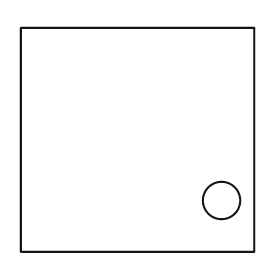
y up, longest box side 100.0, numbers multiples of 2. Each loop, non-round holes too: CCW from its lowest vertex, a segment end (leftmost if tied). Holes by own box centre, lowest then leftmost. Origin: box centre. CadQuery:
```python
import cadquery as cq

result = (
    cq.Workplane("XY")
    .moveTo(-50.0, -48.0)
    .lineTo(50.0, -48.0)
    .lineTo(50.0, 48.0)
    .lineTo(-50.0, 48.0)
    .close()
    .moveTo(36.0, -26.0)
    .circle(8.0)
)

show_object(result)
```